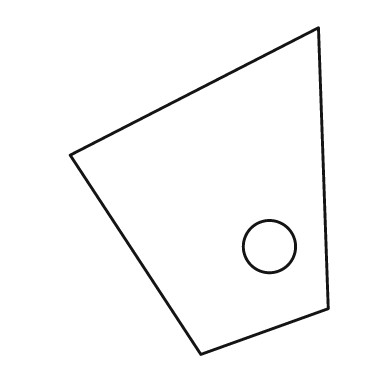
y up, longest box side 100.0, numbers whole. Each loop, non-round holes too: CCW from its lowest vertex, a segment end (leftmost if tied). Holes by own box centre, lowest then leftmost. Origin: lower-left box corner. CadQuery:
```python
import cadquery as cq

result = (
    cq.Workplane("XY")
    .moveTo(40.0, 0.0)
    .lineTo(79.0, 14.0)
    .lineTo(76.0, 100.0)
    .lineTo(0.0, 61.0)
    .close()
    .moveTo(61.0, 33.0)
    .circle(8.0)
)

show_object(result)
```